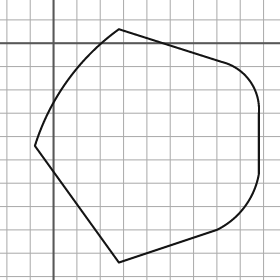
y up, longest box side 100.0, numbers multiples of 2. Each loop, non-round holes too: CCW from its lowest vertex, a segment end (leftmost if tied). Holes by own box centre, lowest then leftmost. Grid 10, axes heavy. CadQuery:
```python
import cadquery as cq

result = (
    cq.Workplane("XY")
    .moveTo(28.0, -94.0)
    .lineTo(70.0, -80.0)
    .threePointArc((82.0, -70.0), (88.0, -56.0))
    .lineTo(88.0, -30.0)
    .threePointArc((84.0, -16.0), (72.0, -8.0))
    .lineTo(28.0, 6.0)
    .threePointArc((6.0, -16.0), (-8.0, -44.0))
    .close()
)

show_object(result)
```